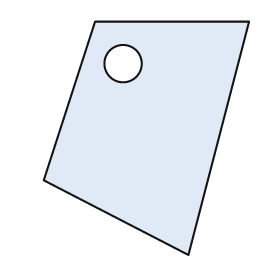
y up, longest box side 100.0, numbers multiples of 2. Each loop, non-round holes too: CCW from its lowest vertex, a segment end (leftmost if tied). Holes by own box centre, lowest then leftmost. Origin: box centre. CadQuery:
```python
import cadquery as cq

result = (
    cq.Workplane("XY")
    .moveTo(18.0, -50.0)
    .lineTo(44.0, 50.0)
    .lineTo(-22.0, 50.0)
    .lineTo(-44.0, -18.0)
    .close()
    .moveTo(-10.0, 32.0)
    .circle(8.0)
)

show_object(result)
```